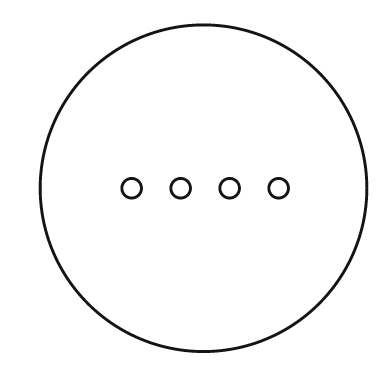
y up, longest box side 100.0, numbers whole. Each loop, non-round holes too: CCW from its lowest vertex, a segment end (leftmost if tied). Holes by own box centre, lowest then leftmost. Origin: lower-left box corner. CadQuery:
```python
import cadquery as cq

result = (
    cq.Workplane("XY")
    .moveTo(50.0, 50.0)
    .circle(50.0)
    .moveTo(28.0, 50.0)
    .circle(3.0)
    .moveTo(43.0, 50.0)
    .circle(3.0)
    .moveTo(58.0, 50.0)
    .circle(3.0)
    .moveTo(73.0, 50.0)
    .circle(3.0)
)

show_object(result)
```